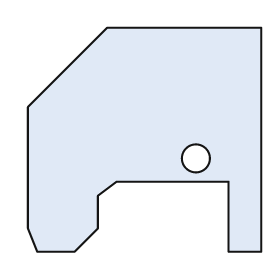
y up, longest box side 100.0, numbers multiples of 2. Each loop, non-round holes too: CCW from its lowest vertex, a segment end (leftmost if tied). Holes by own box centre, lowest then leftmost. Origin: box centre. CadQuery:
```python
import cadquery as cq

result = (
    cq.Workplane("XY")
    .moveTo(-46.0, -48.0)
    .lineTo(-30.0, -48.0)
    .lineTo(-20.0, -38.0)
    .lineTo(-20.0, -24.0)
    .lineTo(-12.0, -18.0)
    .lineTo(36.0, -18.0)
    .lineTo(36.0, -48.0)
    .lineTo(50.0, -48.0)
    .lineTo(50.0, 48.0)
    .lineTo(-16.0, 48.0)
    .lineTo(-50.0, 14.0)
    .lineTo(-50.0, -38.0)
    .close()
    .moveTo(22.0, -8.0)
    .circle(6.0)
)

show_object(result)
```